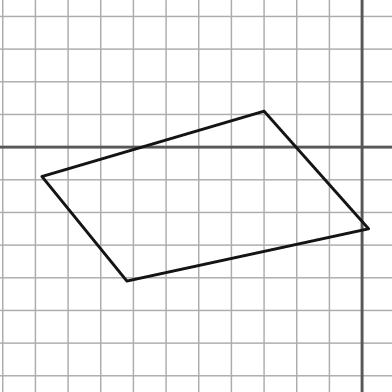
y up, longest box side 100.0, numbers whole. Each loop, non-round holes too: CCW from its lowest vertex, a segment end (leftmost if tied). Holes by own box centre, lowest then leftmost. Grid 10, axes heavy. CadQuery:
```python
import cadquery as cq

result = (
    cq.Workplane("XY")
    .moveTo(-72.0, -41.0)
    .lineTo(2.0, -25.0)
    .lineTo(-30.0, 11.0)
    .lineTo(-98.0, -9.0)
    .close()
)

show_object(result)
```